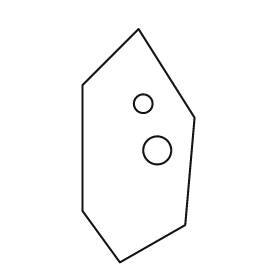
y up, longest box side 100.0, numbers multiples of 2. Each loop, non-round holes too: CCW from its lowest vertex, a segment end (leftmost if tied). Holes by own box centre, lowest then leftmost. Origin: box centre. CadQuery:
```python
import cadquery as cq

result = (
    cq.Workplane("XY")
    .moveTo(-8.0, -50.0)
    .lineTo(20.0, -34.0)
    .lineTo(24.0, 12.0)
    .lineTo(0.0, 50.0)
    .lineTo(-24.0, 26.0)
    .lineTo(-24.0, -28.0)
    .close()
    .moveTo(8.0, -2.0)
    .circle(6.0)
    .moveTo(2.0, 18.0)
    .circle(4.0)
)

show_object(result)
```